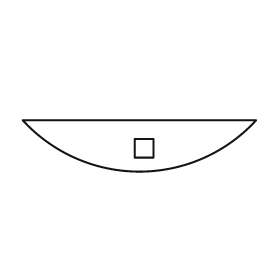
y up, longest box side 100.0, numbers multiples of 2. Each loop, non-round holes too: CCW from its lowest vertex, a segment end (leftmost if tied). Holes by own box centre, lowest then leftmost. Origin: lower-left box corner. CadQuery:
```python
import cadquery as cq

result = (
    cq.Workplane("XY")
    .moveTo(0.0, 22.0)
    .threePointArc((50.0, 0.0), (100.0, 22.0))
    .close()
    .moveTo(48.0, 6.0)
    .lineTo(56.0, 6.0)
    .lineTo(56.0, 14.0)
    .lineTo(48.0, 14.0)
    .close()
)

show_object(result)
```